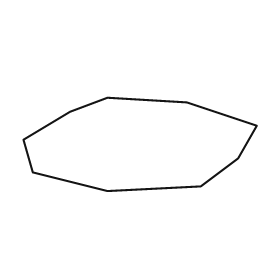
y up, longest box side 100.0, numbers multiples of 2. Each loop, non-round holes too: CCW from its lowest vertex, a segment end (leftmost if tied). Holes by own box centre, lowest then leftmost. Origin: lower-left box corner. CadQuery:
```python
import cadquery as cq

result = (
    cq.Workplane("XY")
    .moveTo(36.0, 0.0)
    .lineTo(76.0, 2.0)
    .lineTo(92.0, 14.0)
    .lineTo(100.0, 28.0)
    .lineTo(70.0, 38.0)
    .lineTo(36.0, 40.0)
    .lineTo(20.0, 34.0)
    .lineTo(0.0, 22.0)
    .lineTo(4.0, 8.0)
    .close()
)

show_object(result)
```